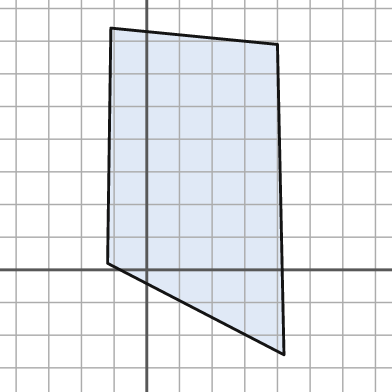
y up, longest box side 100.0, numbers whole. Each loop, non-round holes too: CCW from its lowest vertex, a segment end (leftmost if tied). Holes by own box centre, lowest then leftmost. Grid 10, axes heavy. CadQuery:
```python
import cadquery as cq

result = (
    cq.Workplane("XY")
    .moveTo(42.0, -26.0)
    .lineTo(40.0, 69.0)
    .lineTo(-11.0, 74.0)
    .lineTo(-12.0, 2.0)
    .close()
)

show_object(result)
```